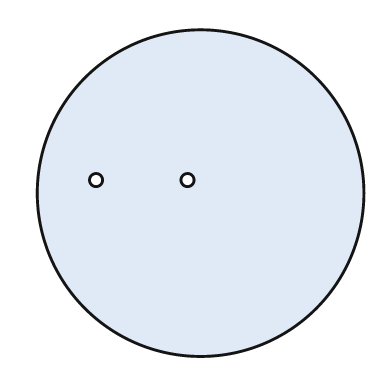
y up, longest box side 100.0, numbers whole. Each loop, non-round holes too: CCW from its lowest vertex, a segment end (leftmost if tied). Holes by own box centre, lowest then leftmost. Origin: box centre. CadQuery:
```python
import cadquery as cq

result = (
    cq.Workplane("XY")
    .moveTo(0.0, 0.0)
    .circle(50.0)
    .moveTo(-32.0, 4.0)
    .circle(2.0)
    .moveTo(-4.0, 4.0)
    .circle(2.0)
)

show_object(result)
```